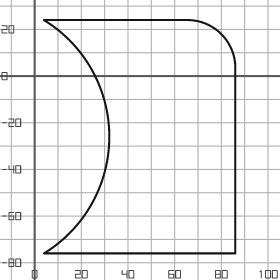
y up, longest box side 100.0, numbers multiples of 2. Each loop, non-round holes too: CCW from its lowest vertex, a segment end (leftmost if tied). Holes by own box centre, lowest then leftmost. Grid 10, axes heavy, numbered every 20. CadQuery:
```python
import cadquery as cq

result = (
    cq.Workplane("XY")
    .moveTo(4.0, -76.0)
    .lineTo(86.0, -76.0)
    .lineTo(86.0, 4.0)
    .threePointArc((80.0, 18.0), (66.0, 24.0))
    .lineTo(4.0, 24.0)
    .threePointArc((32.0, -26.0), (4.0, -76.0))
    .close()
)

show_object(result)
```